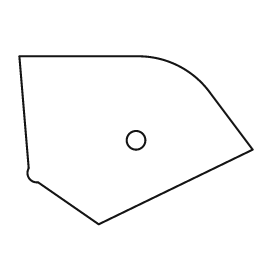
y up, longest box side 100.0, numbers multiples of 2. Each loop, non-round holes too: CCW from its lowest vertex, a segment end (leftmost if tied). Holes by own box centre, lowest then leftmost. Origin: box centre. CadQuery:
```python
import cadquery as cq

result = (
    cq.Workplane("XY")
    .moveTo(-16.0, -36.0)
    .lineTo(50.0, -4.0)
    .lineTo(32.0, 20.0)
    .threePointArc((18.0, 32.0), (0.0, 36.0))
    .lineTo(-50.0, 36.0)
    .lineTo(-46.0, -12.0)
    .threePointArc((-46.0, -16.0), (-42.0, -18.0))
    .close()
    .moveTo(0.0, 0.0)
    .circle(4.0)
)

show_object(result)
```